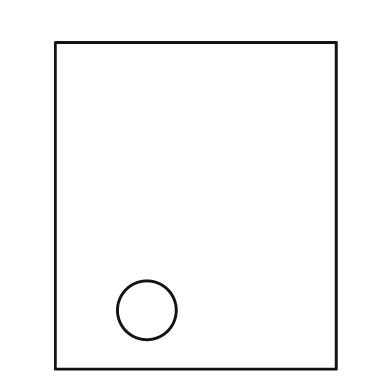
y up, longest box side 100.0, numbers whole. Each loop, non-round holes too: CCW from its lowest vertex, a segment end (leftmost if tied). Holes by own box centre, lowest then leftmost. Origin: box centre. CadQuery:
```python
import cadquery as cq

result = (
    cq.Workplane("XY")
    .moveTo(-43.0, -50.0)
    .lineTo(43.0, -50.0)
    .lineTo(43.0, 50.0)
    .lineTo(-43.0, 50.0)
    .close()
    .moveTo(-15.0, -32.0)
    .circle(9.0)
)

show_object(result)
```